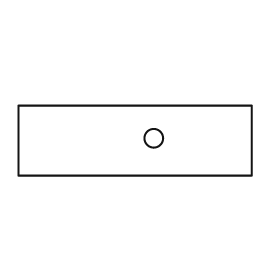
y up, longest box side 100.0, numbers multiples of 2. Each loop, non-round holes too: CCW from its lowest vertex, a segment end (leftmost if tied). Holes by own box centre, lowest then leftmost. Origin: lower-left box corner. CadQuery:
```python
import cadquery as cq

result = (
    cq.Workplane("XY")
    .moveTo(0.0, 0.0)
    .lineTo(100.0, 0.0)
    .lineTo(100.0, 30.0)
    .lineTo(0.0, 30.0)
    .close()
    .moveTo(58.0, 16.0)
    .circle(4.0)
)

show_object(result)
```